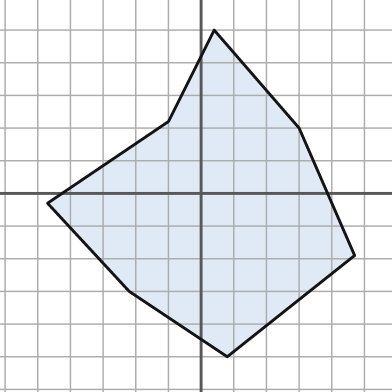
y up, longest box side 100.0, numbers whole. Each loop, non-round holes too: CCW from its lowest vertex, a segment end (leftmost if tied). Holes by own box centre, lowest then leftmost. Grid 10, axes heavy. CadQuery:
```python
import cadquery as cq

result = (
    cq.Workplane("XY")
    .moveTo(8.0, -50.0)
    .lineTo(47.0, -19.0)
    .lineTo(30.0, 20.0)
    .lineTo(4.0, 50.0)
    .lineTo(-10.0, 22.0)
    .lineTo(-47.0, -3.0)
    .lineTo(-22.0, -30.0)
    .close()
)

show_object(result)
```